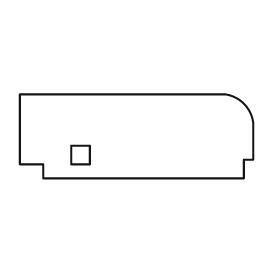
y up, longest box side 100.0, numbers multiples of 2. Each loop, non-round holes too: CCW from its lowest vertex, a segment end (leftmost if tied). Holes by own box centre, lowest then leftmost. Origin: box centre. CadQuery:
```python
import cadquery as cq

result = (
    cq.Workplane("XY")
    .moveTo(-40.0, -18.0)
    .lineTo(46.0, -18.0)
    .lineTo(46.0, -10.0)
    .lineTo(50.0, -10.0)
    .lineTo(50.0, 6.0)
    .threePointArc((46.0, 14.0), (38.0, 18.0))
    .lineTo(-50.0, 18.0)
    .lineTo(-50.0, -12.0)
    .lineTo(-40.0, -12.0)
    .close()
    .moveTo(-28.0, -12.0)
    .lineTo(-20.0, -12.0)
    .lineTo(-20.0, -4.0)
    .lineTo(-28.0, -4.0)
    .close()
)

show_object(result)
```